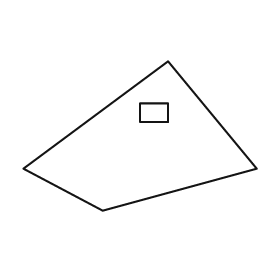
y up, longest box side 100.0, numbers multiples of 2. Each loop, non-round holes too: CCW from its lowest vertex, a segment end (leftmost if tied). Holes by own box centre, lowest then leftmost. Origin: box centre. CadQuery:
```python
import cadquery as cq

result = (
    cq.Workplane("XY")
    .moveTo(-16.0, -32.0)
    .lineTo(50.0, -14.0)
    .lineTo(12.0, 32.0)
    .lineTo(-50.0, -14.0)
    .close()
    .moveTo(0.0, 6.0)
    .lineTo(12.0, 6.0)
    .lineTo(12.0, 14.0)
    .lineTo(0.0, 14.0)
    .close()
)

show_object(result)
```